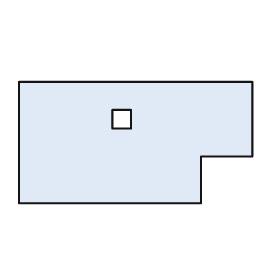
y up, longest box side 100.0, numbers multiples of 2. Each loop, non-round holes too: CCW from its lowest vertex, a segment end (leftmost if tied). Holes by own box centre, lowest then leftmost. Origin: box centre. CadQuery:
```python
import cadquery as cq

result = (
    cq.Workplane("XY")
    .moveTo(-50.0, -26.0)
    .lineTo(28.0, -26.0)
    .lineTo(28.0, -6.0)
    .lineTo(50.0, -6.0)
    .lineTo(50.0, 26.0)
    .lineTo(-50.0, 26.0)
    .close()
    .moveTo(-10.0, 6.0)
    .lineTo(-2.0, 6.0)
    .lineTo(-2.0, 14.0)
    .lineTo(-10.0, 14.0)
    .close()
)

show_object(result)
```